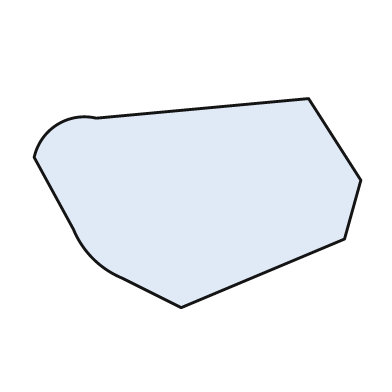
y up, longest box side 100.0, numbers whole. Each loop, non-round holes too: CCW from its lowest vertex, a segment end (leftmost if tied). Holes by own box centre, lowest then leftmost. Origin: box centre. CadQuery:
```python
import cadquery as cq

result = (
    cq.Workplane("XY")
    .moveTo(-5.0, -32.0)
    .lineTo(45.0, -11.0)
    .lineTo(50.0, 7.0)
    .lineTo(34.0, 32.0)
    .lineTo(-31.0, 26.0)
    .threePointArc((-43.0, 24.0), (-50.0, 14.0))
    .lineTo(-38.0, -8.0)
    .threePointArc((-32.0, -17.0), (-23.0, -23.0))
    .close()
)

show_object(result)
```